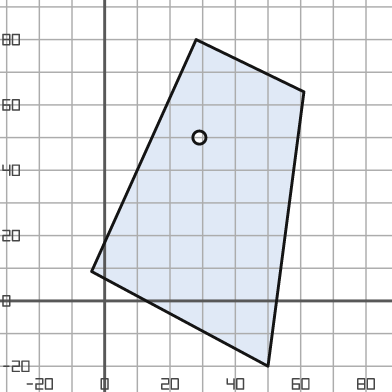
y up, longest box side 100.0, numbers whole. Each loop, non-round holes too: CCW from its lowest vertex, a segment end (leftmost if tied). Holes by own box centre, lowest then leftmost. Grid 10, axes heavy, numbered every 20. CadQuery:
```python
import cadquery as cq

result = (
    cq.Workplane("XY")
    .moveTo(50.0, -20.0)
    .lineTo(61.0, 64.0)
    .lineTo(28.0, 80.0)
    .lineTo(-4.0, 9.0)
    .close()
    .moveTo(29.0, 50.0)
    .circle(2.0)
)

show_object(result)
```